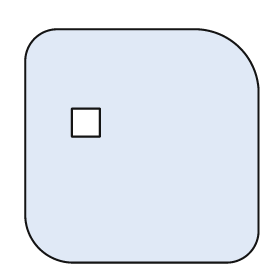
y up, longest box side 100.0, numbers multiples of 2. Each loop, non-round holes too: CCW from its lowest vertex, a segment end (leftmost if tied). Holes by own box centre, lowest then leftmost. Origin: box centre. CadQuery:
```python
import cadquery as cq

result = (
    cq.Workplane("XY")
    .moveTo(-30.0, -50.0)
    .lineTo(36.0, -50.0)
    .threePointArc((46.0, -46.0), (50.0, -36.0))
    .lineTo(50.0, 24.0)
    .threePointArc((42.0, 42.0), (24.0, 50.0))
    .lineTo(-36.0, 50.0)
    .threePointArc((-46.0, 46.0), (-50.0, 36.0))
    .lineTo(-50.0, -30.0)
    .threePointArc((-44.0, -44.0), (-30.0, -50.0))
    .close()
    .moveTo(-30.0, 4.0)
    .lineTo(-18.0, 4.0)
    .lineTo(-18.0, 16.0)
    .lineTo(-30.0, 16.0)
    .close()
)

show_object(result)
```